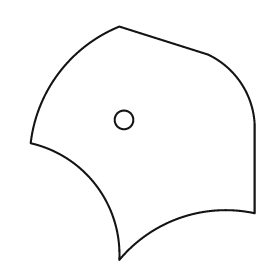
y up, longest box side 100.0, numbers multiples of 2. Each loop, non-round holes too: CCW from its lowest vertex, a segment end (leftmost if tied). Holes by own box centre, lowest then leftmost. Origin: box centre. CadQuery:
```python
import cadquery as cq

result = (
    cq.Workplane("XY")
    .moveTo(-10.0, -50.0)
    .threePointArc((16.0, -32.0), (48.0, -30.0))
    .lineTo(48.0, 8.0)
    .threePointArc((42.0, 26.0), (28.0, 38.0))
    .lineTo(-10.0, 50.0)
    .threePointArc((-36.0, 30.0), (-48.0, 0.0))
    .threePointArc((-20.0, -18.0), (-10.0, -50.0))
    .close()
    .moveTo(-8.0, 10.0)
    .circle(4.0)
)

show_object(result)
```